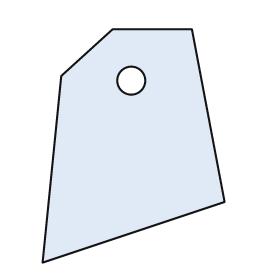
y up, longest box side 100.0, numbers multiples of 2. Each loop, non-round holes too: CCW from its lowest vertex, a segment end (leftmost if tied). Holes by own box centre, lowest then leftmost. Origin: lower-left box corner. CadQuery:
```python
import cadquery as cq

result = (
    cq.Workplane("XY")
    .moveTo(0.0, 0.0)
    .lineTo(78.0, 26.0)
    .lineTo(64.0, 100.0)
    .lineTo(30.0, 100.0)
    .lineTo(8.0, 80.0)
    .close()
    .moveTo(38.0, 78.0)
    .circle(6.0)
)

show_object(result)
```